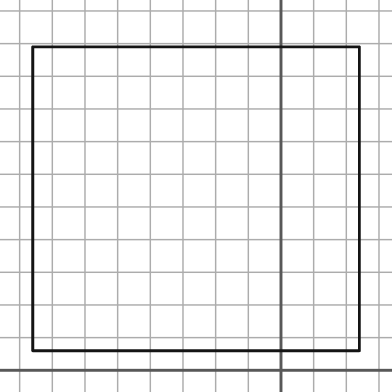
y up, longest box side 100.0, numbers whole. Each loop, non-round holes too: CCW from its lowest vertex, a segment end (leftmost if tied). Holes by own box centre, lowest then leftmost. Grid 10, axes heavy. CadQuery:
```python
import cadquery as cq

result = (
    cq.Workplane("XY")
    .moveTo(-76.0, 6.0)
    .lineTo(24.0, 6.0)
    .lineTo(24.0, 99.0)
    .lineTo(-76.0, 99.0)
    .close()
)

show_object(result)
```